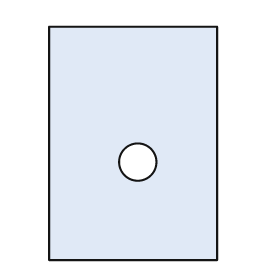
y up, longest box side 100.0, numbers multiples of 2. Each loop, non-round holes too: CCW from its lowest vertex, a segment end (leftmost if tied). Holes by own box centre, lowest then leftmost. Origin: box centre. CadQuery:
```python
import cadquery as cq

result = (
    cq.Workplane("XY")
    .moveTo(-36.0, -50.0)
    .lineTo(36.0, -50.0)
    .lineTo(36.0, 50.0)
    .lineTo(-36.0, 50.0)
    .close()
    .moveTo(2.0, -8.0)
    .circle(8.0)
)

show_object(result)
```